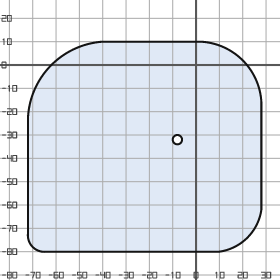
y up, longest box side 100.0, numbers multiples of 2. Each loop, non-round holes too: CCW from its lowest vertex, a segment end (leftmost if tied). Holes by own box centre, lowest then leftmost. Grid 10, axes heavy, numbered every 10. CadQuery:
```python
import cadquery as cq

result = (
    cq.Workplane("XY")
    .moveTo(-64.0, -80.0)
    .lineTo(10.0, -80.0)
    .threePointArc((22.0, -74.0), (28.0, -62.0))
    .lineTo(28.0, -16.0)
    .threePointArc((20.0, 2.0), (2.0, 10.0))
    .lineTo(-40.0, 10.0)
    .threePointArc((-62.0, 0.0), (-72.0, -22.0))
    .lineTo(-72.0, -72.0)
    .threePointArc((-70.0, -78.0), (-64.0, -80.0))
    .close()
    .moveTo(-8.0, -32.0)
    .circle(2.0)
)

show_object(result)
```